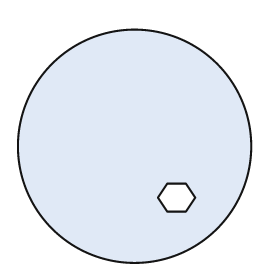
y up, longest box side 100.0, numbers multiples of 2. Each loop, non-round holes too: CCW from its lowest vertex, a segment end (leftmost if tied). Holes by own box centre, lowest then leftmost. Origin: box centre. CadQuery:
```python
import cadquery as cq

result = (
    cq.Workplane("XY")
    .moveTo(0.0, 0.0)
    .circle(50.0)
    .moveTo(14.0, -28.0)
    .lineTo(22.0, -28.0)
    .lineTo(26.0, -22.0)
    .lineTo(22.0, -16.0)
    .lineTo(14.0, -16.0)
    .lineTo(10.0, -22.0)
    .close()
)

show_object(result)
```